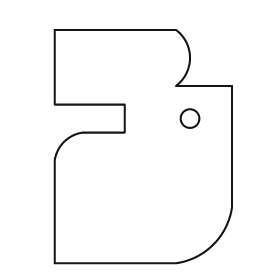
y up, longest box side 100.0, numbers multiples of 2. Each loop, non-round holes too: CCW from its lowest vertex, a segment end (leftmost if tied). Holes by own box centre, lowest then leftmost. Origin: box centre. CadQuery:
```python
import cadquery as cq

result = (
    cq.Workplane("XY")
    .moveTo(-38.0, -50.0)
    .lineTo(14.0, -50.0)
    .threePointArc((30.0, -42.0), (38.0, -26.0))
    .lineTo(38.0, 26.0)
    .lineTo(14.0, 26.0)
    .threePointArc((20.0, 38.0), (14.0, 50.0))
    .lineTo(-38.0, 50.0)
    .lineTo(-38.0, 18.0)
    .lineTo(-8.0, 18.0)
    .lineTo(-8.0, 6.0)
    .lineTo(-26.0, 6.0)
    .threePointArc((-34.0, 2.0), (-38.0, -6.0))
    .close()
    .moveTo(20.0, 12.0)
    .circle(4.0)
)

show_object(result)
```